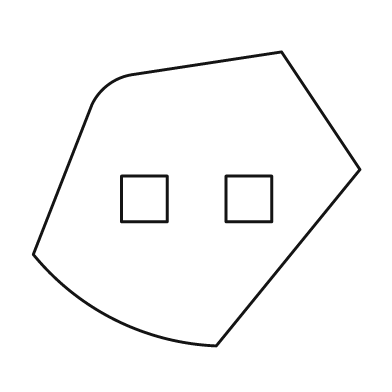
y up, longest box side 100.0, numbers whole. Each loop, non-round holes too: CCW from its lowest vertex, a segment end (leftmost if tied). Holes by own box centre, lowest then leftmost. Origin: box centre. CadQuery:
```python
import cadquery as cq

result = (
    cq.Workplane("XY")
    .moveTo(6.0, -45.0)
    .lineTo(50.0, 9.0)
    .lineTo(26.0, 45.0)
    .lineTo(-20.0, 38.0)
    .threePointArc((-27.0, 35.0), (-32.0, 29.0))
    .lineTo(-50.0, -17.0)
    .threePointArc((-25.0, -37.0), (6.0, -45.0))
    .close()
    .moveTo(-23.0, -7.0)
    .lineTo(-9.0, -7.0)
    .lineTo(-9.0, 7.0)
    .lineTo(-23.0, 7.0)
    .close()
    .moveTo(9.0, -7.0)
    .lineTo(23.0, -7.0)
    .lineTo(23.0, 7.0)
    .lineTo(9.0, 7.0)
    .close()
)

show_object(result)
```